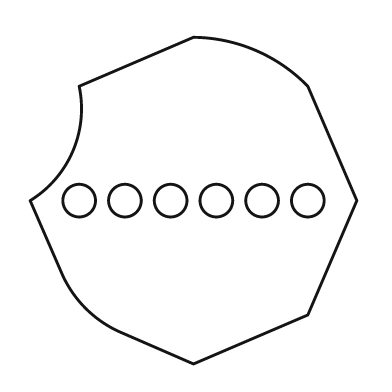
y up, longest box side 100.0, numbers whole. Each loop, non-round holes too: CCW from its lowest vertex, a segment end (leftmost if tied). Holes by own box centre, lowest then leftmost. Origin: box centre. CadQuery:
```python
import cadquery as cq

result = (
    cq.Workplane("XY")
    .moveTo(0.0, -50.0)
    .lineTo(35.0, -35.0)
    .lineTo(50.0, 0.0)
    .lineTo(35.0, 35.0)
    .threePointArc((19.0, 46.0), (0.0, 50.0))
    .lineTo(-35.0, 35.0)
    .threePointArc((-37.0, 15.0), (-50.0, 0.0))
    .lineTo(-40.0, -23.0)
    .threePointArc((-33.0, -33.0), (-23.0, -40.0))
    .close()
    .moveTo(-35.0, 0.0)
    .circle(5.0)
    .moveTo(-21.0, 0.0)
    .circle(5.0)
    .moveTo(-7.0, 0.0)
    .circle(5.0)
    .moveTo(7.0, 0.0)
    .circle(5.0)
    .moveTo(21.0, 0.0)
    .circle(5.0)
    .moveTo(35.0, 0.0)
    .circle(5.0)
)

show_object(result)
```